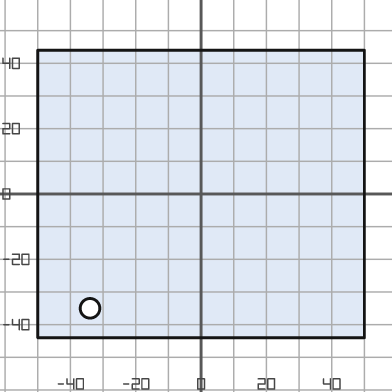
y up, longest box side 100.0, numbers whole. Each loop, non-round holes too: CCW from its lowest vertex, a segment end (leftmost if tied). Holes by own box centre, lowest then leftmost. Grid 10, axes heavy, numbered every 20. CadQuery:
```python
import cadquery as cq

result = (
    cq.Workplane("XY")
    .moveTo(-50.0, -44.0)
    .lineTo(50.0, -44.0)
    .lineTo(50.0, 44.0)
    .lineTo(-50.0, 44.0)
    .close()
    .moveTo(-34.0, -35.0)
    .circle(3.0)
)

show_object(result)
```